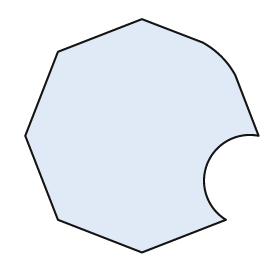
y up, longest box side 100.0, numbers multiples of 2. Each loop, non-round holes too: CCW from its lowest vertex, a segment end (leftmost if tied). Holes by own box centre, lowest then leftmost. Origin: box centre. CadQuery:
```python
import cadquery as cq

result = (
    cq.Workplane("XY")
    .moveTo(0.0, -50.0)
    .lineTo(36.0, -36.0)
    .threePointArc((28.0, -12.0), (50.0, 0.0))
    .lineTo(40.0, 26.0)
    .threePointArc((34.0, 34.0), (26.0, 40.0))
    .lineTo(0.0, 50.0)
    .lineTo(-36.0, 36.0)
    .lineTo(-50.0, 0.0)
    .lineTo(-36.0, -36.0)
    .close()
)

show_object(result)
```